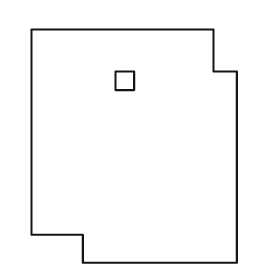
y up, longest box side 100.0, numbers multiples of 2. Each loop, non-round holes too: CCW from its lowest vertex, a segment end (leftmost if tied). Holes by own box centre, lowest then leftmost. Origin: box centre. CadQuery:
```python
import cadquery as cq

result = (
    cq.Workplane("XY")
    .moveTo(-22.0, -50.0)
    .lineTo(44.0, -50.0)
    .lineTo(44.0, 32.0)
    .lineTo(34.0, 32.0)
    .lineTo(34.0, 50.0)
    .lineTo(-44.0, 50.0)
    .lineTo(-44.0, -38.0)
    .lineTo(-22.0, -38.0)
    .close()
    .moveTo(-8.0, 24.0)
    .lineTo(0.0, 24.0)
    .lineTo(0.0, 32.0)
    .lineTo(-8.0, 32.0)
    .close()
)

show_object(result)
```